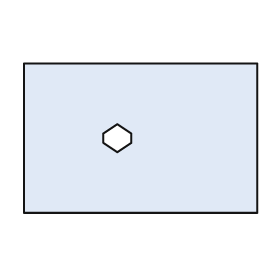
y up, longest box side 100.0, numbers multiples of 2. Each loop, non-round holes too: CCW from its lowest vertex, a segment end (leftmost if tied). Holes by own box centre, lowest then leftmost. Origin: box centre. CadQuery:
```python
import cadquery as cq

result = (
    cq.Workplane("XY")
    .moveTo(-50.0, -32.0)
    .lineTo(50.0, -32.0)
    .lineTo(50.0, 32.0)
    .lineTo(-50.0, 32.0)
    .close()
    .moveTo(-10.0, -6.0)
    .lineTo(-4.0, -2.0)
    .lineTo(-4.0, 2.0)
    .lineTo(-10.0, 6.0)
    .lineTo(-16.0, 2.0)
    .lineTo(-16.0, -2.0)
    .close()
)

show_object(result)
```